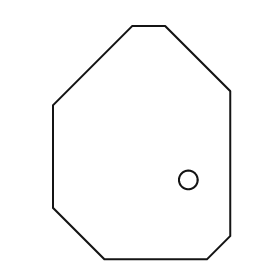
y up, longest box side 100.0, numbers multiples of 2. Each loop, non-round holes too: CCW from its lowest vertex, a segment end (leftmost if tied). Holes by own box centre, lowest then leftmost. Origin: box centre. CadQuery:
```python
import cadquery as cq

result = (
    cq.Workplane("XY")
    .moveTo(-16.0, -50.0)
    .lineTo(28.0, -50.0)
    .lineTo(38.0, -40.0)
    .lineTo(38.0, 22.0)
    .lineTo(10.0, 50.0)
    .lineTo(-4.0, 50.0)
    .lineTo(-38.0, 16.0)
    .lineTo(-38.0, -28.0)
    .close()
    .moveTo(20.0, -16.0)
    .circle(4.0)
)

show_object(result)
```